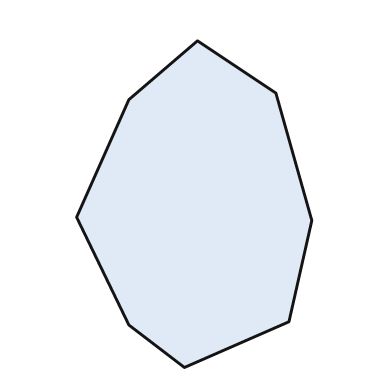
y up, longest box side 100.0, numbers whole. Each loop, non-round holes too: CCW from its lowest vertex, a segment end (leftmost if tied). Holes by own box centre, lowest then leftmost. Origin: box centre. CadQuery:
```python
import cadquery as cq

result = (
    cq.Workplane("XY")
    .moveTo(-3.0, -50.0)
    .lineTo(29.0, -36.0)
    .lineTo(36.0, -5.0)
    .lineTo(25.0, 34.0)
    .lineTo(1.0, 50.0)
    .lineTo(-20.0, 32.0)
    .lineTo(-36.0, -4.0)
    .lineTo(-20.0, -37.0)
    .close()
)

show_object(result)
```